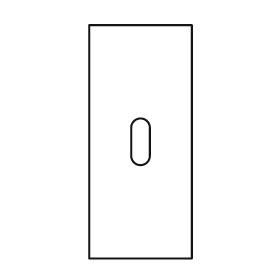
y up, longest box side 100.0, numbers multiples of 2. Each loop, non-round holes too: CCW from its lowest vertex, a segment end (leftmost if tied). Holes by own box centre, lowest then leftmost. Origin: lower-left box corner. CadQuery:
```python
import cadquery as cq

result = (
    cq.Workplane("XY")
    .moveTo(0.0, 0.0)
    .lineTo(44.0, 0.0)
    .lineTo(44.0, 100.0)
    .lineTo(0.0, 100.0)
    .close()
    .moveTo(18.0, 44.0)
    .threePointArc((22.0, 40.0), (26.0, 44.0))
    .lineTo(26.0, 56.0)
    .threePointArc((22.0, 60.0), (18.0, 56.0))
    .close()
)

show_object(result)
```